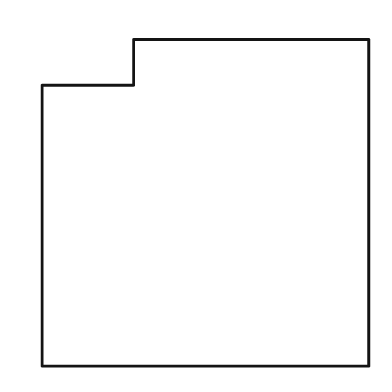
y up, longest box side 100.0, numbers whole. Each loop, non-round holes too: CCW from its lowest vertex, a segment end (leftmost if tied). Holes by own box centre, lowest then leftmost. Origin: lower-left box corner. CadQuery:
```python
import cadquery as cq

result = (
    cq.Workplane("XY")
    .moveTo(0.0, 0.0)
    .lineTo(100.0, 0.0)
    .lineTo(100.0, 100.0)
    .lineTo(28.0, 100.0)
    .lineTo(28.0, 86.0)
    .lineTo(0.0, 86.0)
    .close()
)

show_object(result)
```